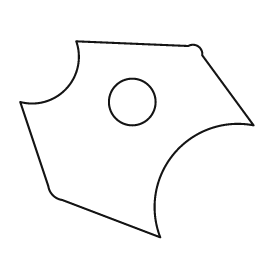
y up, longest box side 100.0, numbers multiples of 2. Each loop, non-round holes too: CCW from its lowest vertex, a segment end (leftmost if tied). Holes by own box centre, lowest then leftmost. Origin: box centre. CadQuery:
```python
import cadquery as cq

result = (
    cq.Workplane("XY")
    .moveTo(10.0, -42.0)
    .threePointArc((16.0, -6.0), (50.0, 6.0))
    .lineTo(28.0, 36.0)
    .threePointArc((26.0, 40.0), (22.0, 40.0))
    .lineTo(-26.0, 42.0)
    .threePointArc((-30.0, 22.0), (-50.0, 16.0))
    .lineTo(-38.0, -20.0)
    .threePointArc((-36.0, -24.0), (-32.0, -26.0))
    .close()
    .moveTo(-2.0, 16.0)
    .circle(10.0)
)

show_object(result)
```